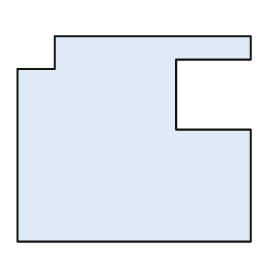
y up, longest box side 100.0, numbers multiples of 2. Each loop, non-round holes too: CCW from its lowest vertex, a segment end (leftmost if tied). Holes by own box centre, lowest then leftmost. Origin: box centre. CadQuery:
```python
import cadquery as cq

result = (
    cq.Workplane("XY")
    .moveTo(-50.0, -44.0)
    .lineTo(50.0, -44.0)
    .lineTo(50.0, 4.0)
    .lineTo(18.0, 4.0)
    .lineTo(18.0, 34.0)
    .lineTo(50.0, 34.0)
    .lineTo(50.0, 44.0)
    .lineTo(-34.0, 44.0)
    .lineTo(-34.0, 30.0)
    .lineTo(-50.0, 30.0)
    .close()
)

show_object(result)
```